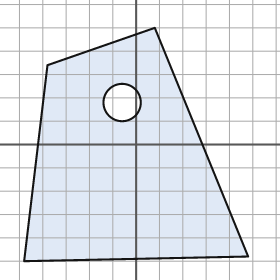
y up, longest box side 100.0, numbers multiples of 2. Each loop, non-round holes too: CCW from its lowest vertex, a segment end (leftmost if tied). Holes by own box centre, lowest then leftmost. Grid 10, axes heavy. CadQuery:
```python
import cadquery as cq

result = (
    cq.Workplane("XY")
    .moveTo(-48.0, -50.0)
    .lineTo(48.0, -48.0)
    .lineTo(8.0, 50.0)
    .lineTo(-38.0, 34.0)
    .close()
    .moveTo(-6.0, 18.0)
    .circle(8.0)
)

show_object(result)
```